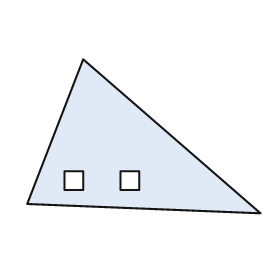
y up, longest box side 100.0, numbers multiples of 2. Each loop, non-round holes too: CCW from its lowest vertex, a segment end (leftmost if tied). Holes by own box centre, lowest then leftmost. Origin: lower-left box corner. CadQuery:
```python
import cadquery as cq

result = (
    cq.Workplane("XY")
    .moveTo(100.0, 0.0)
    .lineTo(24.0, 66.0)
    .lineTo(0.0, 4.0)
    .close()
    .moveTo(16.0, 10.0)
    .lineTo(24.0, 10.0)
    .lineTo(24.0, 18.0)
    .lineTo(16.0, 18.0)
    .close()
    .moveTo(40.0, 10.0)
    .lineTo(48.0, 10.0)
    .lineTo(48.0, 18.0)
    .lineTo(40.0, 18.0)
    .close()
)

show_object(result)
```